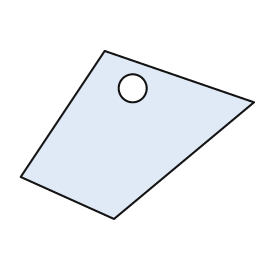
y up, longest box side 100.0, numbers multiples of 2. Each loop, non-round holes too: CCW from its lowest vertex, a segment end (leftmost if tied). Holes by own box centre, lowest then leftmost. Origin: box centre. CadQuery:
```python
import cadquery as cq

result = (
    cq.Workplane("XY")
    .moveTo(-10.0, -36.0)
    .lineTo(50.0, 14.0)
    .lineTo(-14.0, 36.0)
    .lineTo(-50.0, -18.0)
    .close()
    .moveTo(-2.0, 20.0)
    .circle(6.0)
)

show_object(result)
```